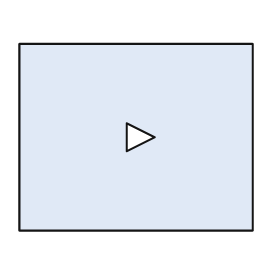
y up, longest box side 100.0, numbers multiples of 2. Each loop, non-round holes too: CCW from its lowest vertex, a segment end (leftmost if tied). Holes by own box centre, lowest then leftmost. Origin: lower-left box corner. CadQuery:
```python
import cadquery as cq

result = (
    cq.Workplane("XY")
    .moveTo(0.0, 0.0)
    .lineTo(100.0, 0.0)
    .lineTo(100.0, 80.0)
    .lineTo(0.0, 80.0)
    .close()
    .moveTo(46.0, 34.0)
    .lineTo(58.0, 40.0)
    .lineTo(46.0, 46.0)
    .close()
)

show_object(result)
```